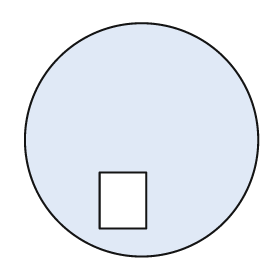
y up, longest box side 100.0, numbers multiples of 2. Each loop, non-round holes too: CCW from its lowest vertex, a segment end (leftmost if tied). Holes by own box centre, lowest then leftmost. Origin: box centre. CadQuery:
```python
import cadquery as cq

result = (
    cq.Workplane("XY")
    .moveTo(0.0, 0.0)
    .circle(50.0)
    .moveTo(-18.0, -38.0)
    .lineTo(2.0, -38.0)
    .lineTo(2.0, -14.0)
    .lineTo(-18.0, -14.0)
    .close()
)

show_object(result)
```